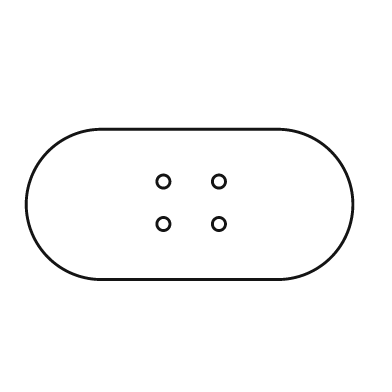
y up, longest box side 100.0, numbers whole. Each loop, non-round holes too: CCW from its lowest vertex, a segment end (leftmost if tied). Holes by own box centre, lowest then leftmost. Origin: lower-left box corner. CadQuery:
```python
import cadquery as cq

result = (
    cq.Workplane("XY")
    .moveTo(23.0, 0.0)
    .lineTo(77.0, 0.0)
    .threePointArc((100.0, 23.0), (77.0, 46.0))
    .lineTo(23.0, 46.0)
    .threePointArc((0.0, 23.0), (23.0, 0.0))
    .close()
    .moveTo(42.0, 17.0)
    .circle(2.0)
    .moveTo(59.0, 17.0)
    .circle(2.0)
    .moveTo(42.0, 30.0)
    .circle(2.0)
    .moveTo(59.0, 30.0)
    .circle(2.0)
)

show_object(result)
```